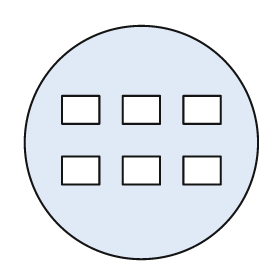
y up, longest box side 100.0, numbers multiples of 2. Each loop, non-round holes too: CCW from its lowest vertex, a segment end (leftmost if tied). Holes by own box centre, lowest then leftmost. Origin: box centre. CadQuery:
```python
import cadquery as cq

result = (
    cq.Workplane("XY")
    .moveTo(0.0, 0.0)
    .circle(50.0)
    .moveTo(-34.0, -18.0)
    .lineTo(-18.0, -18.0)
    .lineTo(-18.0, -6.0)
    .lineTo(-34.0, -6.0)
    .close()
    .moveTo(-8.0, -18.0)
    .lineTo(8.0, -18.0)
    .lineTo(8.0, -6.0)
    .lineTo(-8.0, -6.0)
    .close()
    .moveTo(18.0, -18.0)
    .lineTo(34.0, -18.0)
    .lineTo(34.0, -6.0)
    .lineTo(18.0, -6.0)
    .close()
    .moveTo(-34.0, 8.0)
    .lineTo(-18.0, 8.0)
    .lineTo(-18.0, 20.0)
    .lineTo(-34.0, 20.0)
    .close()
    .moveTo(-8.0, 8.0)
    .lineTo(8.0, 8.0)
    .lineTo(8.0, 20.0)
    .lineTo(-8.0, 20.0)
    .close()
    .moveTo(18.0, 8.0)
    .lineTo(34.0, 8.0)
    .lineTo(34.0, 20.0)
    .lineTo(18.0, 20.0)
    .close()
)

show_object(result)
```